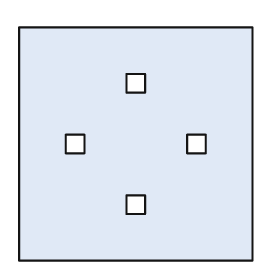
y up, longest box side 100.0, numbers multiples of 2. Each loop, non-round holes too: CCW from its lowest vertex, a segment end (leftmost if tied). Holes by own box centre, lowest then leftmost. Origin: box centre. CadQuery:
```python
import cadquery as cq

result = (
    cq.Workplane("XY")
    .moveTo(-50.0, -50.0)
    .lineTo(50.0, -50.0)
    .lineTo(50.0, 50.0)
    .lineTo(-50.0, 50.0)
    .close()
    .moveTo(-4.0, -30.0)
    .lineTo(4.0, -30.0)
    .lineTo(4.0, -22.0)
    .lineTo(-4.0, -22.0)
    .close()
    .moveTo(-30.0, -4.0)
    .lineTo(-22.0, -4.0)
    .lineTo(-22.0, 4.0)
    .lineTo(-30.0, 4.0)
    .close()
    .moveTo(22.0, -4.0)
    .lineTo(30.0, -4.0)
    .lineTo(30.0, 4.0)
    .lineTo(22.0, 4.0)
    .close()
    .moveTo(-4.0, 22.0)
    .lineTo(4.0, 22.0)
    .lineTo(4.0, 30.0)
    .lineTo(-4.0, 30.0)
    .close()
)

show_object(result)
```